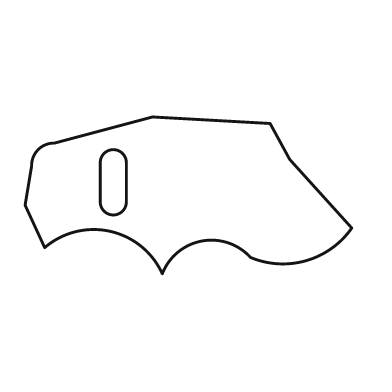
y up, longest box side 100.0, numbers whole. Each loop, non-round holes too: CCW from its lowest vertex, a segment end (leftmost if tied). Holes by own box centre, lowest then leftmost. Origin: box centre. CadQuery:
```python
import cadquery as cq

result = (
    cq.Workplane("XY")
    .moveTo(-8.0, -24.0)
    .threePointArc((4.0, -14.0), (19.0, -19.0))
    .threePointArc((36.0, -20.0), (50.0, -10.0))
    .lineTo(31.0, 11.0)
    .lineTo(25.0, 22.0)
    .lineTo(-11.0, 24.0)
    .lineTo(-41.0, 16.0)
    .threePointArc((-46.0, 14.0), (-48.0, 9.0))
    .lineTo(-50.0, -3.0)
    .lineTo(-44.0, -16.0)
    .threePointArc((-24.0, -11.0), (-8.0, -24.0))
    .close()
    .moveTo(-27.0, -2.0)
    .threePointArc((-23.0, -6.0), (-19.0, -2.0))
    .lineTo(-19.0, 10.0)
    .threePointArc((-23.0, 14.0), (-27.0, 10.0))
    .close()
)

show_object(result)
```